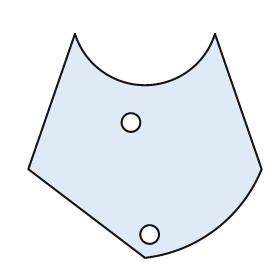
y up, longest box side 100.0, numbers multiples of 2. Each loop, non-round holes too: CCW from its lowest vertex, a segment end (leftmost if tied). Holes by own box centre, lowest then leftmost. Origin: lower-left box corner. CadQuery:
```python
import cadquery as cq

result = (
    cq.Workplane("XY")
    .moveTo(50.0, 0.0)
    .threePointArc((80.0, 12.0), (100.0, 38.0))
    .lineTo(80.0, 96.0)
    .threePointArc((50.0, 74.0), (20.0, 96.0))
    .lineTo(0.0, 38.0)
    .close()
    .moveTo(52.0, 10.0)
    .circle(4.0)
    .moveTo(44.0, 58.0)
    .circle(4.0)
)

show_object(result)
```